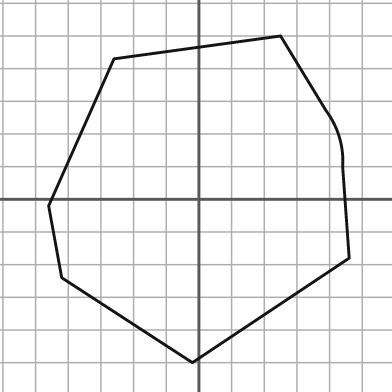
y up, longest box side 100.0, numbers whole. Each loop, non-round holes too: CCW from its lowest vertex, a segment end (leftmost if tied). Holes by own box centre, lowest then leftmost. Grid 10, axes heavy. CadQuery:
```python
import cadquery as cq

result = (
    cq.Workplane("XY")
    .moveTo(-2.0, -50.0)
    .lineTo(46.0, -18.0)
    .lineTo(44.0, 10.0)
    .threePointArc((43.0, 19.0), (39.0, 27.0))
    .lineTo(25.0, 50.0)
    .lineTo(-26.0, 43.0)
    .lineTo(-46.0, -2.0)
    .lineTo(-42.0, -24.0)
    .close()
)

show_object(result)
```